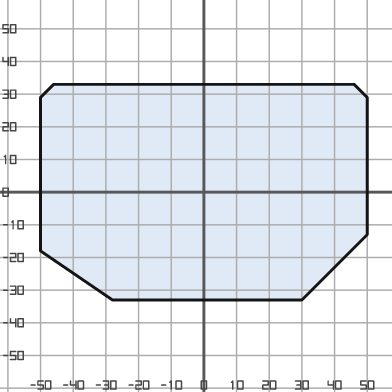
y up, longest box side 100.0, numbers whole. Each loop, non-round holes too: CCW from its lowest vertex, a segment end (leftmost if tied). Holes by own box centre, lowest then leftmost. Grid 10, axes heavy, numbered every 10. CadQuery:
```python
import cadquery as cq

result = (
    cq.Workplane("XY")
    .moveTo(-28.0, -33.0)
    .lineTo(30.0, -33.0)
    .lineTo(50.0, -13.0)
    .lineTo(50.0, 29.0)
    .lineTo(46.0, 33.0)
    .lineTo(-46.0, 33.0)
    .lineTo(-50.0, 29.0)
    .lineTo(-50.0, -18.0)
    .close()
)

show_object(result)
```